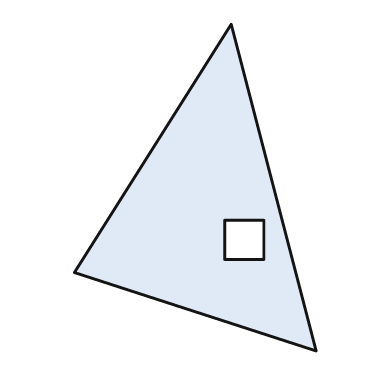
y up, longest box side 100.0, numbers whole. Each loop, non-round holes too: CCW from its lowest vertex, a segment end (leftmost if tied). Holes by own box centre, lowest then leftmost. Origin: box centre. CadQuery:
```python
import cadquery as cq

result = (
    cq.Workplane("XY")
    .moveTo(37.0, -50.0)
    .lineTo(11.0, 50.0)
    .lineTo(-37.0, -26.0)
    .close()
    .moveTo(9.0, -22.0)
    .lineTo(21.0, -22.0)
    .lineTo(21.0, -10.0)
    .lineTo(9.0, -10.0)
    .close()
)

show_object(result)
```